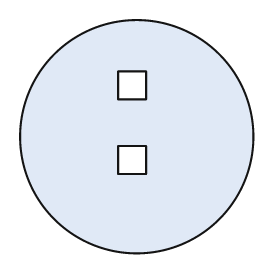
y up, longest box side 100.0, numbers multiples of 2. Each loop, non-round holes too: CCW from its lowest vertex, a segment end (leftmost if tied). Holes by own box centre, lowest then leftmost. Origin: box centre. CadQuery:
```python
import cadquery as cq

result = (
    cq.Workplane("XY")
    .moveTo(0.0, 0.0)
    .circle(50.0)
    .moveTo(-8.0, -16.0)
    .lineTo(4.0, -16.0)
    .lineTo(4.0, -4.0)
    .lineTo(-8.0, -4.0)
    .close()
    .moveTo(-8.0, 16.0)
    .lineTo(4.0, 16.0)
    .lineTo(4.0, 28.0)
    .lineTo(-8.0, 28.0)
    .close()
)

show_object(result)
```